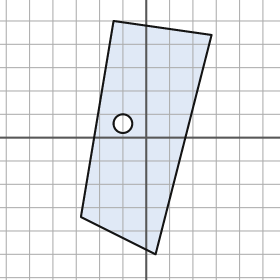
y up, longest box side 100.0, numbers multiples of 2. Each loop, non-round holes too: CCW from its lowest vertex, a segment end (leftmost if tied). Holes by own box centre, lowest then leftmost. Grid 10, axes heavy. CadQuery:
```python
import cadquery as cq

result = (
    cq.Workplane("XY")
    .moveTo(4.0, -50.0)
    .lineTo(28.0, 44.0)
    .lineTo(-14.0, 50.0)
    .lineTo(-28.0, -34.0)
    .close()
    .moveTo(-10.0, 6.0)
    .circle(4.0)
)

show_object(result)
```